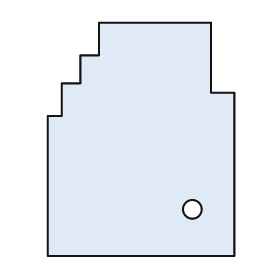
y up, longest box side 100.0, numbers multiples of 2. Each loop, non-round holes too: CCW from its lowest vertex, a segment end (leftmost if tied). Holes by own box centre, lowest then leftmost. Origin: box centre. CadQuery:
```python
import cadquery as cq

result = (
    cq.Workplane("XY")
    .moveTo(-40.0, -50.0)
    .lineTo(40.0, -50.0)
    .lineTo(40.0, 20.0)
    .lineTo(30.0, 20.0)
    .lineTo(30.0, 50.0)
    .lineTo(-18.0, 50.0)
    .lineTo(-18.0, 36.0)
    .lineTo(-26.0, 36.0)
    .lineTo(-26.0, 24.0)
    .lineTo(-34.0, 24.0)
    .lineTo(-34.0, 10.0)
    .lineTo(-40.0, 10.0)
    .close()
    .moveTo(22.0, -30.0)
    .circle(4.0)
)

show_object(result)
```